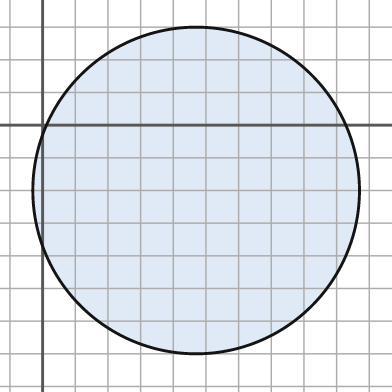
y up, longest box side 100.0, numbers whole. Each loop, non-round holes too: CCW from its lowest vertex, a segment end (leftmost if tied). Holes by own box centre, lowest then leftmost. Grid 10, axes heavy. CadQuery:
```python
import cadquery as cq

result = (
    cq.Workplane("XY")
    .moveTo(47.0, -20.0)
    .circle(50.0)
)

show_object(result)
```